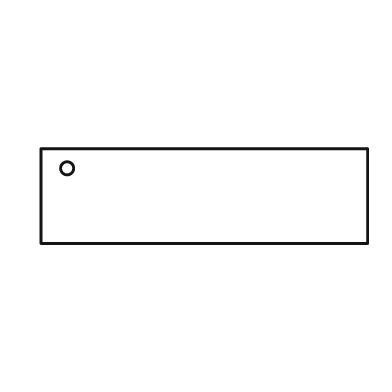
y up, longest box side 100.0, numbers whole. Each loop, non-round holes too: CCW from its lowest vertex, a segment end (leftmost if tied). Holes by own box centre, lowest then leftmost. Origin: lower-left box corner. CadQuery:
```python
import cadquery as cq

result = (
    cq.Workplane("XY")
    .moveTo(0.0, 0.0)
    .lineTo(100.0, 0.0)
    .lineTo(100.0, 29.0)
    .lineTo(0.0, 29.0)
    .close()
    .moveTo(8.0, 23.0)
    .circle(2.0)
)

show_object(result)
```